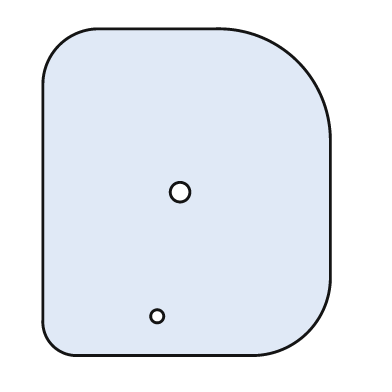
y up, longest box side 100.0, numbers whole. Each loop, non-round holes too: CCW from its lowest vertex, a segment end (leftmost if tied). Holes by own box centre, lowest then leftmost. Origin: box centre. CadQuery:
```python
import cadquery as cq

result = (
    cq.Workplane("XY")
    .moveTo(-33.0, -50.0)
    .lineTo(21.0, -50.0)
    .threePointArc((37.0, -43.0), (44.0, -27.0))
    .lineTo(44.0, 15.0)
    .threePointArc((34.0, 40.0), (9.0, 50.0))
    .lineTo(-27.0, 50.0)
    .threePointArc((-39.0, 45.0), (-44.0, 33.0))
    .lineTo(-44.0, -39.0)
    .threePointArc((-41.0, -47.0), (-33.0, -50.0))
    .close()
    .moveTo(-9.0, -38.0)
    .circle(2.0)
    .moveTo(-2.0, 0.0)
    .circle(3.0)
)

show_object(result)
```